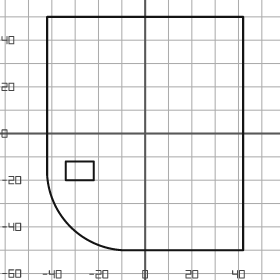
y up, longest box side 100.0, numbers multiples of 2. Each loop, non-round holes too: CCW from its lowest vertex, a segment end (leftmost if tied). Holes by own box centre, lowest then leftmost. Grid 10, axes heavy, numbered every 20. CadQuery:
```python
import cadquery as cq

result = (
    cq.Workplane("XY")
    .moveTo(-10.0, -50.0)
    .lineTo(42.0, -50.0)
    .lineTo(42.0, 50.0)
    .lineTo(-42.0, 50.0)
    .lineTo(-42.0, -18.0)
    .threePointArc((-32.0, -40.0), (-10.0, -50.0))
    .close()
    .moveTo(-34.0, -20.0)
    .lineTo(-22.0, -20.0)
    .lineTo(-22.0, -12.0)
    .lineTo(-34.0, -12.0)
    .close()
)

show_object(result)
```